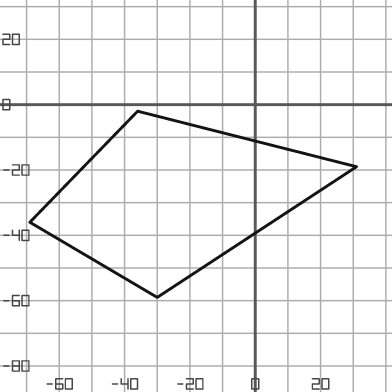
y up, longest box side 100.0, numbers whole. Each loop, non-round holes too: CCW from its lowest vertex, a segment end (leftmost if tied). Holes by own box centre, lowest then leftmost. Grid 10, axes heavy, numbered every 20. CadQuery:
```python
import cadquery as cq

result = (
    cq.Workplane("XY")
    .moveTo(-30.0, -59.0)
    .lineTo(31.0, -19.0)
    .lineTo(-36.0, -2.0)
    .lineTo(-69.0, -36.0)
    .close()
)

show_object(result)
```